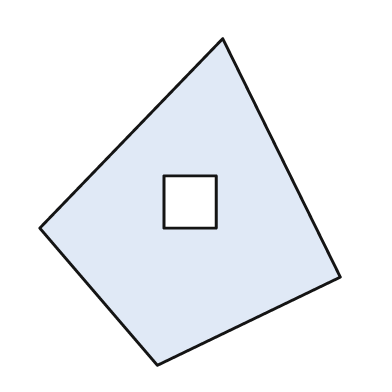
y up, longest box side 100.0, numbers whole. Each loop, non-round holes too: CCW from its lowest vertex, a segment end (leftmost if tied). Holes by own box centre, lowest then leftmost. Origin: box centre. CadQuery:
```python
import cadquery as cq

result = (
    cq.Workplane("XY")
    .moveTo(-10.0, -50.0)
    .lineTo(46.0, -23.0)
    .lineTo(10.0, 50.0)
    .lineTo(-46.0, -8.0)
    .close()
    .moveTo(-8.0, -8.0)
    .lineTo(8.0, -8.0)
    .lineTo(8.0, 8.0)
    .lineTo(-8.0, 8.0)
    .close()
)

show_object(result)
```